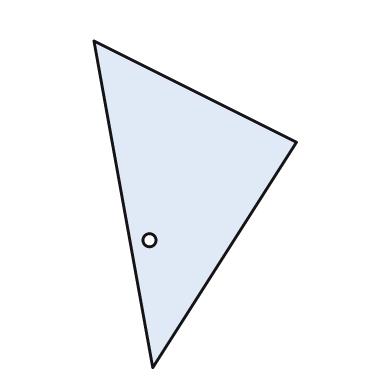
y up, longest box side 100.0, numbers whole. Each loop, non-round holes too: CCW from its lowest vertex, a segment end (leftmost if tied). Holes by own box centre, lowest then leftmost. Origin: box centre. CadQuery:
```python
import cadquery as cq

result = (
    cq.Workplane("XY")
    .moveTo(-13.0, -50.0)
    .lineTo(31.0, 19.0)
    .lineTo(-31.0, 50.0)
    .close()
    .moveTo(-14.0, -11.0)
    .circle(2.0)
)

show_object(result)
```